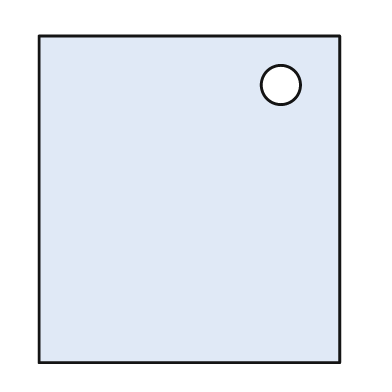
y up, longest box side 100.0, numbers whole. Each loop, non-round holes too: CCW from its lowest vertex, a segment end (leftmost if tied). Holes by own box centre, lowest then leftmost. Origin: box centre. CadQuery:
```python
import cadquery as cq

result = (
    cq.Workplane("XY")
    .moveTo(-46.0, -50.0)
    .lineTo(46.0, -50.0)
    .lineTo(46.0, 50.0)
    .lineTo(-46.0, 50.0)
    .close()
    .moveTo(28.0, 35.0)
    .circle(6.0)
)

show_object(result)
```